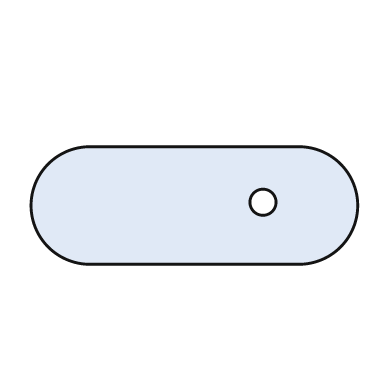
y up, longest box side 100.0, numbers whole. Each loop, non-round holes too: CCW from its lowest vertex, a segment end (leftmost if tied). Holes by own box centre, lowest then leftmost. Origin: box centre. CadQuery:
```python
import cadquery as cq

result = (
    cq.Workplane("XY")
    .moveTo(-32.0, -18.0)
    .lineTo(32.0, -18.0)
    .threePointArc((50.0, 0.0), (32.0, 18.0))
    .lineTo(-32.0, 18.0)
    .threePointArc((-50.0, 0.0), (-32.0, -18.0))
    .close()
    .moveTo(21.0, 1.0)
    .circle(4.0)
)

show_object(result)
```